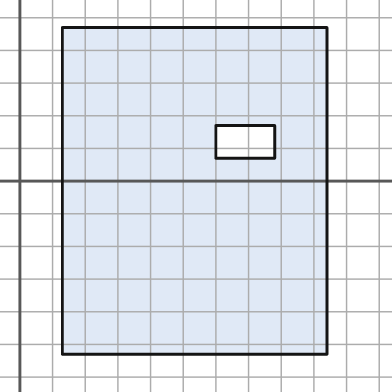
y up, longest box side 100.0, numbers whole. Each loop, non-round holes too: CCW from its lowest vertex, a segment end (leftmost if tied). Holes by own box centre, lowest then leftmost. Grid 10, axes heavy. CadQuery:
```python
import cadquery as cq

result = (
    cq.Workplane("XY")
    .moveTo(13.0, -53.0)
    .lineTo(94.0, -53.0)
    .lineTo(94.0, 47.0)
    .lineTo(13.0, 47.0)
    .close()
    .moveTo(60.0, 7.0)
    .lineTo(78.0, 7.0)
    .lineTo(78.0, 17.0)
    .lineTo(60.0, 17.0)
    .close()
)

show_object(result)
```